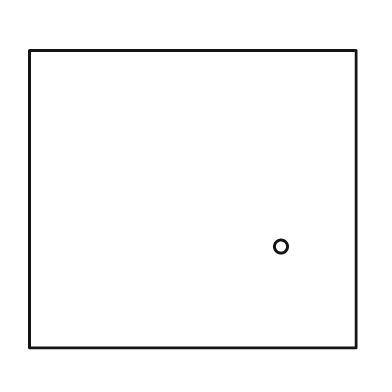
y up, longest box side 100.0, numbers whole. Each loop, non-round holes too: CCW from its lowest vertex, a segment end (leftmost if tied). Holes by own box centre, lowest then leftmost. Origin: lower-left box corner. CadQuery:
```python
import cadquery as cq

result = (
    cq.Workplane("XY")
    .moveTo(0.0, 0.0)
    .lineTo(100.0, 0.0)
    .lineTo(100.0, 91.0)
    .lineTo(0.0, 91.0)
    .close()
    .moveTo(77.0, 31.0)
    .circle(2.0)
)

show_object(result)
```